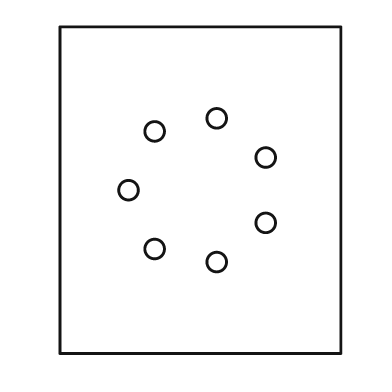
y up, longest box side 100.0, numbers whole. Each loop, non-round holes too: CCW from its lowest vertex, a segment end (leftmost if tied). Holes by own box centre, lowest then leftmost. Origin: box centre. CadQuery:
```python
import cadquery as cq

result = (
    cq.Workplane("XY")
    .moveTo(-43.0, -50.0)
    .lineTo(43.0, -50.0)
    .lineTo(43.0, 50.0)
    .lineTo(-43.0, 50.0)
    .close()
    .moveTo(5.0, -22.0)
    .circle(3.0)
    .moveTo(-14.0, -18.0)
    .circle(3.0)
    .moveTo(20.0, -10.0)
    .circle(3.0)
    .moveTo(-22.0, 0.0)
    .circle(3.0)
    .moveTo(20.0, 10.0)
    .circle(3.0)
    .moveTo(-14.0, 18.0)
    .circle(3.0)
    .moveTo(5.0, 22.0)
    .circle(3.0)
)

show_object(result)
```